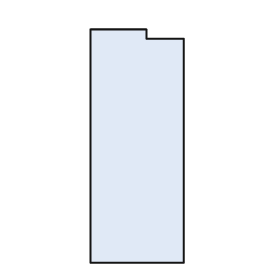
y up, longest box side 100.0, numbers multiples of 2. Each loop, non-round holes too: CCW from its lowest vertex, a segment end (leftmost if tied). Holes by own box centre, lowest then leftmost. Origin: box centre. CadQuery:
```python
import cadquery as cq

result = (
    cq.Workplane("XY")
    .moveTo(-20.0, -50.0)
    .lineTo(20.0, -50.0)
    .lineTo(20.0, 46.0)
    .lineTo(4.0, 46.0)
    .lineTo(4.0, 50.0)
    .lineTo(-20.0, 50.0)
    .close()
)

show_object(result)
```